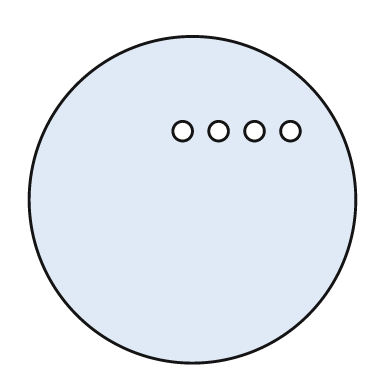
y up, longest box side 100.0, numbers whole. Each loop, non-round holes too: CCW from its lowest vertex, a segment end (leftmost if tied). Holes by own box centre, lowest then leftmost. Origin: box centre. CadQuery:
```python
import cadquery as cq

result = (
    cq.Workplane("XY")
    .moveTo(0.0, 0.0)
    .circle(50.0)
    .moveTo(-3.0, 21.0)
    .circle(3.0)
    .moveTo(8.0, 21.0)
    .circle(3.0)
    .moveTo(19.0, 21.0)
    .circle(3.0)
    .moveTo(30.0, 21.0)
    .circle(3.0)
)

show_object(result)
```